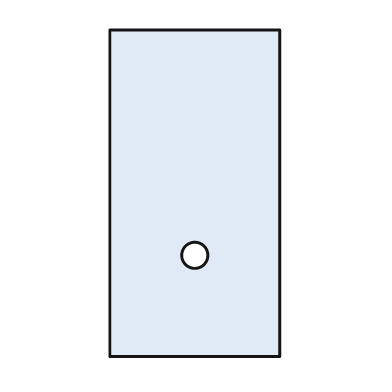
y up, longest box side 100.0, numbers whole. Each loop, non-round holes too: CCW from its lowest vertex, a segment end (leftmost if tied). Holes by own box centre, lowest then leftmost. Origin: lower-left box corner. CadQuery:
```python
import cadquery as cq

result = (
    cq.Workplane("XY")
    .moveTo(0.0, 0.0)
    .lineTo(52.0, 0.0)
    .lineTo(52.0, 100.0)
    .lineTo(0.0, 100.0)
    .close()
    .moveTo(26.0, 31.0)
    .circle(4.0)
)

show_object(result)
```